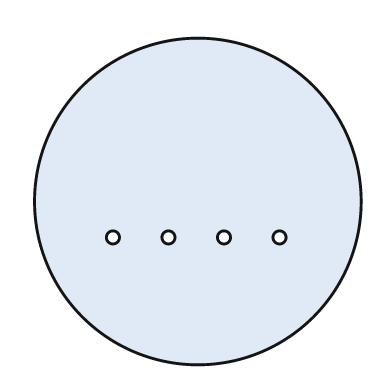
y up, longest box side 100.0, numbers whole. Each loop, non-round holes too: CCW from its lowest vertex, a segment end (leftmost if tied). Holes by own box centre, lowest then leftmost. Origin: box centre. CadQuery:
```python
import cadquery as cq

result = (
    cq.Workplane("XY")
    .moveTo(0.0, 0.0)
    .circle(50.0)
    .moveTo(-26.0, -11.0)
    .circle(2.0)
    .moveTo(-9.0, -11.0)
    .circle(2.0)
    .moveTo(8.0, -11.0)
    .circle(2.0)
    .moveTo(25.0, -11.0)
    .circle(2.0)
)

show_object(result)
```